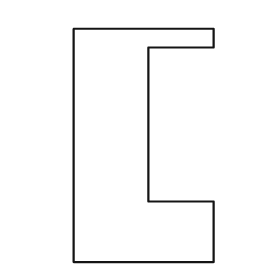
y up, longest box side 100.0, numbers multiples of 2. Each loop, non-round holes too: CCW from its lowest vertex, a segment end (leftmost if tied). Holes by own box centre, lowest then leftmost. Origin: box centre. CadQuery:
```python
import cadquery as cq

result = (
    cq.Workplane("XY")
    .moveTo(-30.0, -50.0)
    .lineTo(30.0, -50.0)
    .lineTo(30.0, -24.0)
    .lineTo(2.0, -24.0)
    .lineTo(2.0, 42.0)
    .lineTo(30.0, 42.0)
    .lineTo(30.0, 50.0)
    .lineTo(-30.0, 50.0)
    .close()
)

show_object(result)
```